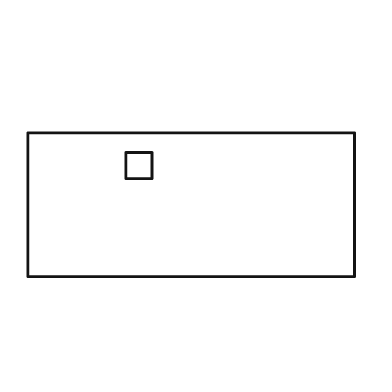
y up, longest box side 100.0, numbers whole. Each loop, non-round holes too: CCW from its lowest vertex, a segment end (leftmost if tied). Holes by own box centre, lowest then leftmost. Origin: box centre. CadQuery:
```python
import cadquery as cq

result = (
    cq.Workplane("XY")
    .moveTo(-50.0, -22.0)
    .lineTo(50.0, -22.0)
    .lineTo(50.0, 22.0)
    .lineTo(-50.0, 22.0)
    .close()
    .moveTo(-20.0, 8.0)
    .lineTo(-12.0, 8.0)
    .lineTo(-12.0, 16.0)
    .lineTo(-20.0, 16.0)
    .close()
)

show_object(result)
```